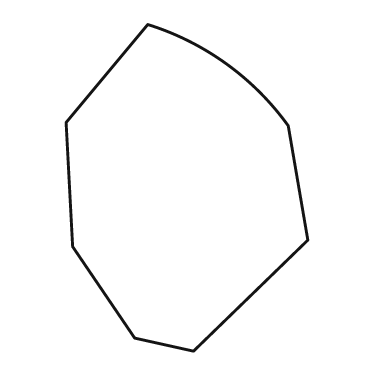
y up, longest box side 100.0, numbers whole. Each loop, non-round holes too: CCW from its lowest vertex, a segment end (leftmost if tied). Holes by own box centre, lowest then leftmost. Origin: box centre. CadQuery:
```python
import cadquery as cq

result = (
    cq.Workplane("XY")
    .moveTo(2.0, -50.0)
    .lineTo(37.0, -16.0)
    .lineTo(31.0, 19.0)
    .threePointArc((12.0, 38.0), (-12.0, 50.0))
    .lineTo(-37.0, 20.0)
    .lineTo(-35.0, -18.0)
    .lineTo(-16.0, -46.0)
    .close()
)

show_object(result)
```